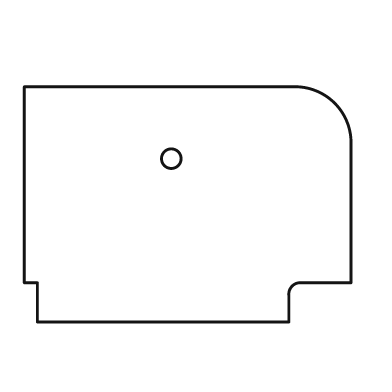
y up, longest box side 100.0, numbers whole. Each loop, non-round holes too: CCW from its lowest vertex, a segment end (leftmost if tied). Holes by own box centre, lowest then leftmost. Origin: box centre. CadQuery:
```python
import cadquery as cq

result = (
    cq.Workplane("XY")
    .moveTo(-46.0, -36.0)
    .lineTo(31.0, -36.0)
    .lineTo(31.0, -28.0)
    .threePointArc((32.0, -25.0), (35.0, -24.0))
    .lineTo(50.0, -24.0)
    .lineTo(50.0, 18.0)
    .threePointArc((45.0, 31.0), (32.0, 36.0))
    .lineTo(-50.0, 36.0)
    .lineTo(-50.0, -24.0)
    .lineTo(-46.0, -24.0)
    .close()
    .moveTo(-5.0, 14.0)
    .circle(3.0)
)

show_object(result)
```